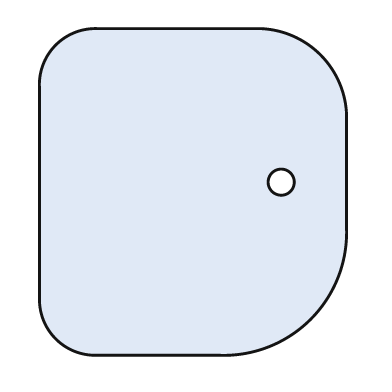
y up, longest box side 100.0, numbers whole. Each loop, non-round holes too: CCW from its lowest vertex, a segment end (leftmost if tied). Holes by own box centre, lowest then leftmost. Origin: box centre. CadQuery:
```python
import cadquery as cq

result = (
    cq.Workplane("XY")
    .moveTo(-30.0, -50.0)
    .lineTo(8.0, -50.0)
    .threePointArc((36.0, -39.0), (47.0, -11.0))
    .lineTo(47.0, 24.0)
    .threePointArc((39.0, 42.0), (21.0, 50.0))
    .lineTo(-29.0, 50.0)
    .threePointArc((-42.0, 45.0), (-47.0, 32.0))
    .lineTo(-47.0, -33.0)
    .threePointArc((-42.0, -45.0), (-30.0, -50.0))
    .close()
    .moveTo(27.0, 3.0)
    .circle(4.0)
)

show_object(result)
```